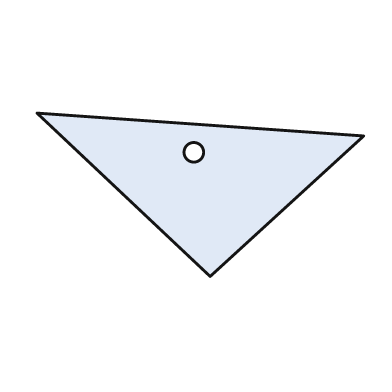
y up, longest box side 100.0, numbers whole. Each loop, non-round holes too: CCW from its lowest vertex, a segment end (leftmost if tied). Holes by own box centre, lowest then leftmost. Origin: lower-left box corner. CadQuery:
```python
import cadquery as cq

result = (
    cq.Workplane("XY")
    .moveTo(53.0, 0.0)
    .lineTo(100.0, 43.0)
    .lineTo(0.0, 50.0)
    .close()
    .moveTo(48.0, 38.0)
    .circle(3.0)
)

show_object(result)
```